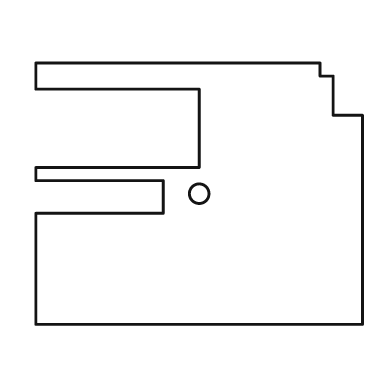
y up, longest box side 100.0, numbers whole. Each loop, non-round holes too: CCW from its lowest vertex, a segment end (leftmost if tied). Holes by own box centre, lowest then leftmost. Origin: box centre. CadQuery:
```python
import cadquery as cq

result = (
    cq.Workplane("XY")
    .moveTo(-50.0, -40.0)
    .lineTo(50.0, -40.0)
    .lineTo(50.0, 24.0)
    .lineTo(41.0, 24.0)
    .lineTo(41.0, 36.0)
    .lineTo(37.0, 36.0)
    .lineTo(37.0, 40.0)
    .lineTo(-50.0, 40.0)
    .lineTo(-50.0, 32.0)
    .lineTo(0.0, 32.0)
    .lineTo(0.0, 8.0)
    .lineTo(-50.0, 8.0)
    .lineTo(-50.0, 4.0)
    .lineTo(-11.0, 4.0)
    .lineTo(-11.0, -6.0)
    .lineTo(-50.0, -6.0)
    .close()
    .moveTo(0.0, 0.0)
    .circle(3.0)
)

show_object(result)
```